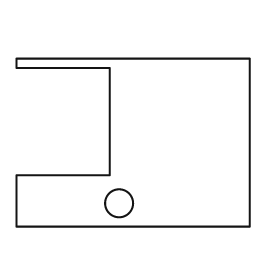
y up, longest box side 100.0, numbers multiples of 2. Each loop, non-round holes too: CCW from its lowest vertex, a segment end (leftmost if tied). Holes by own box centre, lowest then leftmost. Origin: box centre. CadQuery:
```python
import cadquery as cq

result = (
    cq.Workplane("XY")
    .moveTo(-50.0, -36.0)
    .lineTo(50.0, -36.0)
    .lineTo(50.0, 36.0)
    .lineTo(-50.0, 36.0)
    .lineTo(-50.0, 32.0)
    .lineTo(-10.0, 32.0)
    .lineTo(-10.0, -14.0)
    .lineTo(-50.0, -14.0)
    .close()
    .moveTo(-6.0, -26.0)
    .circle(6.0)
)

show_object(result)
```